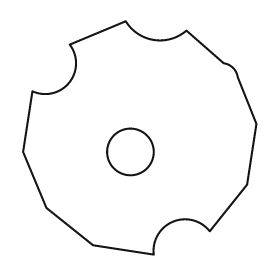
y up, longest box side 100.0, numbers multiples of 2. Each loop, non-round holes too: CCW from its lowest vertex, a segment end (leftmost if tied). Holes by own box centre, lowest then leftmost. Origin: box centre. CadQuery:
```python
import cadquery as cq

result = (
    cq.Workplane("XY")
    .moveTo(6.0, -50.0)
    .threePointArc((14.0, -36.0), (30.0, -40.0))
    .lineTo(46.0, -20.0)
    .lineTo(50.0, 6.0)
    .lineTo(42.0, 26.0)
    .threePointArc((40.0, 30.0), (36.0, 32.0))
    .lineTo(20.0, 46.0)
    .threePointArc((6.0, 42.0), (-6.0, 50.0))
    .lineTo(-30.0, 40.0)
    .threePointArc((-30.0, 24.0), (-46.0, 20.0))
    .lineTo(-50.0, -6.0)
    .lineTo(-40.0, -30.0)
    .lineTo(-20.0, -46.0)
    .close()
    .moveTo(-4.0, -6.0)
    .circle(10.0)
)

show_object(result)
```